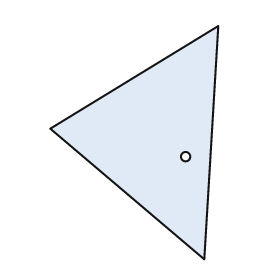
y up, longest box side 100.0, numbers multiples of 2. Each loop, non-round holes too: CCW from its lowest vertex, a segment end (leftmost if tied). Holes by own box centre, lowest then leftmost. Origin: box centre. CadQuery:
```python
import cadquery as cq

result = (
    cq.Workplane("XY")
    .moveTo(30.0, -50.0)
    .lineTo(36.0, 50.0)
    .lineTo(-36.0, 6.0)
    .close()
    .moveTo(22.0, -6.0)
    .circle(2.0)
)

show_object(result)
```